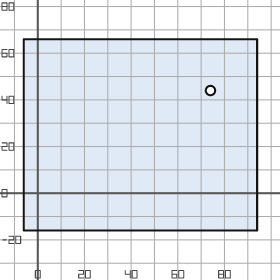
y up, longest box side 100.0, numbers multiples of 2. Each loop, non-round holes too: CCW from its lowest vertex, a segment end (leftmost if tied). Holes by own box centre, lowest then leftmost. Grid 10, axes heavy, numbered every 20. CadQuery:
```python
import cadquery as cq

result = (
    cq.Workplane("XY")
    .moveTo(-6.0, -16.0)
    .lineTo(94.0, -16.0)
    .lineTo(94.0, 66.0)
    .lineTo(-6.0, 66.0)
    .close()
    .moveTo(74.0, 44.0)
    .circle(2.0)
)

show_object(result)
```